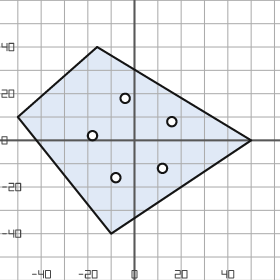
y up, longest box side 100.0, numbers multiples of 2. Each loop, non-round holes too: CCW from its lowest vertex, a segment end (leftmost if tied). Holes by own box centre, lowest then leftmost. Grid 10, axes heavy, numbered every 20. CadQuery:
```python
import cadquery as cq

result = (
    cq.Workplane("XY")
    .moveTo(-10.0, -40.0)
    .lineTo(50.0, 0.0)
    .lineTo(-16.0, 40.0)
    .lineTo(-50.0, 10.0)
    .close()
    .moveTo(-8.0, -16.0)
    .circle(2.0)
    .moveTo(12.0, -12.0)
    .circle(2.0)
    .moveTo(-18.0, 2.0)
    .circle(2.0)
    .moveTo(16.0, 8.0)
    .circle(2.0)
    .moveTo(-4.0, 18.0)
    .circle(2.0)
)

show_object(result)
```